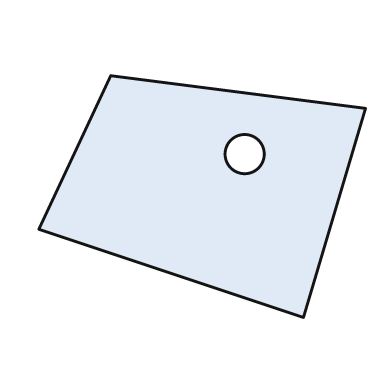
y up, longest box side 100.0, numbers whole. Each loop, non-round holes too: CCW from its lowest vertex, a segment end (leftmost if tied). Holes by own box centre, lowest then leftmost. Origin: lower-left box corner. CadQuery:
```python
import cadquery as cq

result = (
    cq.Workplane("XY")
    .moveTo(81.0, 0.0)
    .lineTo(100.0, 64.0)
    .lineTo(22.0, 74.0)
    .lineTo(0.0, 27.0)
    .close()
    .moveTo(63.0, 50.0)
    .circle(6.0)
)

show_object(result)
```